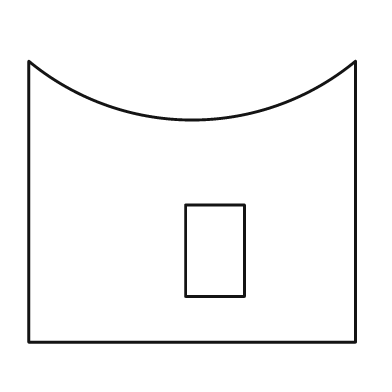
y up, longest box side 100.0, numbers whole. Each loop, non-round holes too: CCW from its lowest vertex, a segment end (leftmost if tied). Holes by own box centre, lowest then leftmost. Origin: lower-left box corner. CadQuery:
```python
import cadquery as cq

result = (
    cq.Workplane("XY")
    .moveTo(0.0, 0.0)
    .lineTo(100.0, 0.0)
    .lineTo(100.0, 86.0)
    .threePointArc((50.0, 68.0), (0.0, 86.0))
    .close()
    .moveTo(48.0, 14.0)
    .lineTo(66.0, 14.0)
    .lineTo(66.0, 42.0)
    .lineTo(48.0, 42.0)
    .close()
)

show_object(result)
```